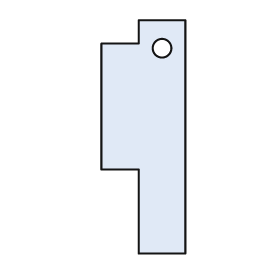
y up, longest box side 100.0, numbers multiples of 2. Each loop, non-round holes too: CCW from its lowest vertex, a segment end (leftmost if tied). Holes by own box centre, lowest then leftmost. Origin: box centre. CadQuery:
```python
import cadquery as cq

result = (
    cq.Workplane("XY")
    .moveTo(-2.0, -50.0)
    .lineTo(18.0, -50.0)
    .lineTo(18.0, 50.0)
    .lineTo(-2.0, 50.0)
    .lineTo(-2.0, 40.0)
    .lineTo(-18.0, 40.0)
    .lineTo(-18.0, -14.0)
    .lineTo(-2.0, -14.0)
    .close()
    .moveTo(8.0, 38.0)
    .circle(4.0)
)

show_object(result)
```